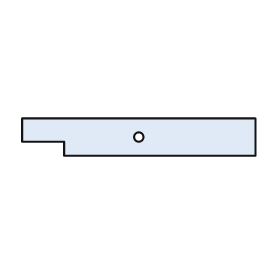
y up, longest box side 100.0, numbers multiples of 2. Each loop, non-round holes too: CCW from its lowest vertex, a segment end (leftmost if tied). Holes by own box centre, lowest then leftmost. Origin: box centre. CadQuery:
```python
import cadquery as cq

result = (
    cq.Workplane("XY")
    .moveTo(-32.0, -8.0)
    .lineTo(50.0, -8.0)
    .lineTo(50.0, 8.0)
    .lineTo(-50.0, 8.0)
    .lineTo(-50.0, -2.0)
    .lineTo(-32.0, -2.0)
    .close()
    .moveTo(0.0, 0.0)
    .circle(2.0)
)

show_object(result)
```